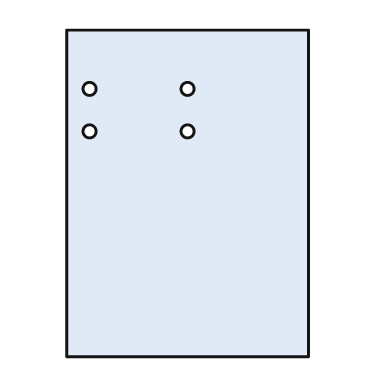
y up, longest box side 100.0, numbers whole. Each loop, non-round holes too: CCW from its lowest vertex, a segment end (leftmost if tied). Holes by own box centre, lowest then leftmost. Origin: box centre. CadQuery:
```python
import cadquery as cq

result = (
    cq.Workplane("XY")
    .moveTo(-37.0, -50.0)
    .lineTo(37.0, -50.0)
    .lineTo(37.0, 50.0)
    .lineTo(-37.0, 50.0)
    .close()
    .moveTo(-30.0, 19.0)
    .circle(2.0)
    .moveTo(0.0, 19.0)
    .circle(2.0)
    .moveTo(-30.0, 32.0)
    .circle(2.0)
    .moveTo(0.0, 32.0)
    .circle(2.0)
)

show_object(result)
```